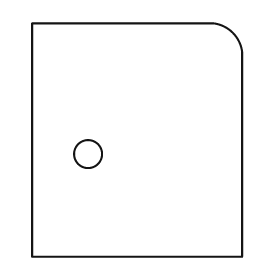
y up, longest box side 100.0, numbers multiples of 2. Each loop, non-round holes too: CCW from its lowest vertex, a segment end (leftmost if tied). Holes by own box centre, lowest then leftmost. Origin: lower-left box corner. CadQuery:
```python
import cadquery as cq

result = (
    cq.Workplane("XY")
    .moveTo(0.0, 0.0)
    .lineTo(90.0, 0.0)
    .lineTo(90.0, 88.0)
    .threePointArc((86.0, 96.0), (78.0, 100.0))
    .lineTo(0.0, 100.0)
    .close()
    .moveTo(24.0, 44.0)
    .circle(6.0)
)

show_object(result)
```